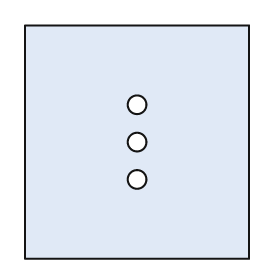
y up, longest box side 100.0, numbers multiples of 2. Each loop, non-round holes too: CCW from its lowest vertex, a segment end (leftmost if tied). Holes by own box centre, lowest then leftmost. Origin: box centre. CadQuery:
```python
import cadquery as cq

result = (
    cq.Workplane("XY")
    .moveTo(-48.0, -50.0)
    .lineTo(48.0, -50.0)
    .lineTo(48.0, 50.0)
    .lineTo(-48.0, 50.0)
    .close()
    .moveTo(0.0, -16.0)
    .circle(4.0)
    .moveTo(0.0, 0.0)
    .circle(4.0)
    .moveTo(0.0, 16.0)
    .circle(4.0)
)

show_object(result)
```